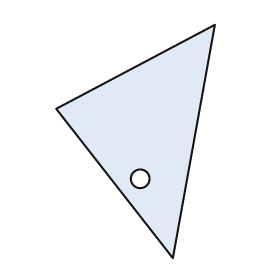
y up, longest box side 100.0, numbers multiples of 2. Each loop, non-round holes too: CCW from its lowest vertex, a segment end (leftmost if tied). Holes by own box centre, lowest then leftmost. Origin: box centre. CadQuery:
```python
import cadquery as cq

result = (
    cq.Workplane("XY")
    .moveTo(16.0, -50.0)
    .lineTo(34.0, 50.0)
    .lineTo(-34.0, 14.0)
    .close()
    .moveTo(2.0, -16.0)
    .circle(4.0)
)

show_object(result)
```